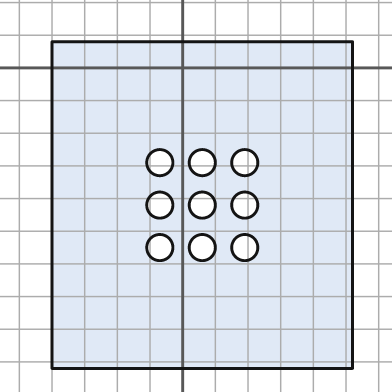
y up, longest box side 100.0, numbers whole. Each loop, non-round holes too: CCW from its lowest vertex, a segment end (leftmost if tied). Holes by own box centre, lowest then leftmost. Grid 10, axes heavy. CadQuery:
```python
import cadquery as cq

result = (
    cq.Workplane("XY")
    .moveTo(-40.0, -92.0)
    .lineTo(52.0, -92.0)
    .lineTo(52.0, 8.0)
    .lineTo(-40.0, 8.0)
    .close()
    .moveTo(-7.0, -55.0)
    .circle(4.0)
    .moveTo(6.0, -55.0)
    .circle(4.0)
    .moveTo(19.0, -55.0)
    .circle(4.0)
    .moveTo(-7.0, -42.0)
    .circle(4.0)
    .moveTo(6.0, -42.0)
    .circle(4.0)
    .moveTo(19.0, -42.0)
    .circle(4.0)
    .moveTo(-7.0, -29.0)
    .circle(4.0)
    .moveTo(6.0, -29.0)
    .circle(4.0)
    .moveTo(19.0, -29.0)
    .circle(4.0)
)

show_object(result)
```